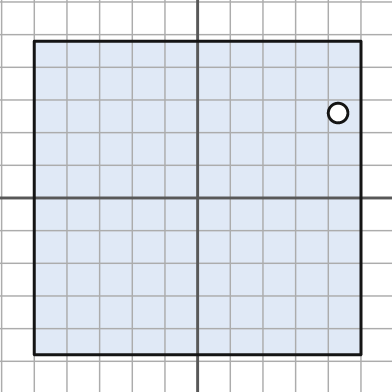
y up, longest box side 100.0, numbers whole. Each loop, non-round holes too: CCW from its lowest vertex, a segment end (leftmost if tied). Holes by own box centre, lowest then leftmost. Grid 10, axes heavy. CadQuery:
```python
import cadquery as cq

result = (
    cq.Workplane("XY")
    .moveTo(-50.0, -48.0)
    .lineTo(50.0, -48.0)
    .lineTo(50.0, 48.0)
    .lineTo(-50.0, 48.0)
    .close()
    .moveTo(43.0, 26.0)
    .circle(3.0)
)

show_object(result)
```